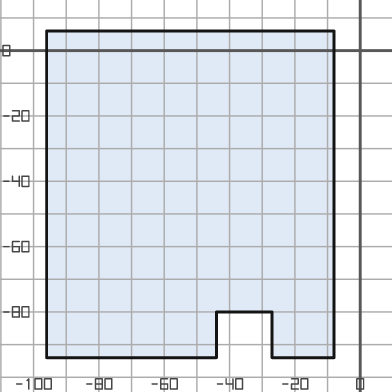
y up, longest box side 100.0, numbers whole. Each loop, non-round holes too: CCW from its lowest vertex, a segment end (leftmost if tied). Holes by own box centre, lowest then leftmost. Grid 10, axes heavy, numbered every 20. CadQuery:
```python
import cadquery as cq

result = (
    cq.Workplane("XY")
    .moveTo(-96.0, -94.0)
    .lineTo(-44.0, -94.0)
    .lineTo(-44.0, -80.0)
    .lineTo(-27.0, -80.0)
    .lineTo(-27.0, -94.0)
    .lineTo(-8.0, -94.0)
    .lineTo(-8.0, 6.0)
    .lineTo(-96.0, 6.0)
    .close()
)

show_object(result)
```